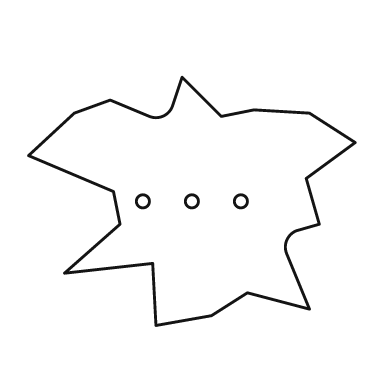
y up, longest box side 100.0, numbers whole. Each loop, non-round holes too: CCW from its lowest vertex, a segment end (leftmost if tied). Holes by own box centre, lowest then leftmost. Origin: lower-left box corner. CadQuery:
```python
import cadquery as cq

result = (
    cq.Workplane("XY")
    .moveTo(39.0, 0.0)
    .lineTo(56.0, 3.0)
    .lineTo(67.0, 10.0)
    .lineTo(86.0, 5.0)
    .lineTo(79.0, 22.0)
    .threePointArc((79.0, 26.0), (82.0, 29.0))
    .lineTo(89.0, 31.0)
    .lineTo(85.0, 45.0)
    .lineTo(100.0, 56.0)
    .lineTo(86.0, 65.0)
    .lineTo(69.0, 66.0)
    .lineTo(59.0, 64.0)
    .lineTo(47.0, 76.0)
    .lineTo(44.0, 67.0)
    .threePointArc((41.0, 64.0), (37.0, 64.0))
    .lineTo(25.0, 69.0)
    .lineTo(14.0, 65.0)
    .lineTo(0.0, 52.0)
    .lineTo(26.0, 41.0)
    .lineTo(28.0, 31.0)
    .lineTo(11.0, 16.0)
    .lineTo(38.0, 19.0)
    .close()
    .moveTo(35.0, 38.0)
    .circle(2.0)
    .moveTo(50.0, 38.0)
    .circle(2.0)
    .moveTo(65.0, 38.0)
    .circle(2.0)
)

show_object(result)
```